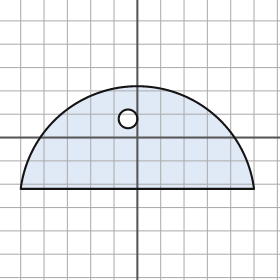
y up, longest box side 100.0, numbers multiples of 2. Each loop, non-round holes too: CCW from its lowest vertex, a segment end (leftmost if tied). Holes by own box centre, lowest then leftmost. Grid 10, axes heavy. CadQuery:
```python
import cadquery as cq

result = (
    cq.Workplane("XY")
    .moveTo(-50.0, -22.0)
    .lineTo(50.0, -22.0)
    .threePointArc((0.0, 22.0), (-50.0, -22.0))
    .close()
    .moveTo(-4.0, 8.0)
    .circle(4.0)
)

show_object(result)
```